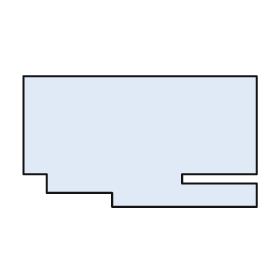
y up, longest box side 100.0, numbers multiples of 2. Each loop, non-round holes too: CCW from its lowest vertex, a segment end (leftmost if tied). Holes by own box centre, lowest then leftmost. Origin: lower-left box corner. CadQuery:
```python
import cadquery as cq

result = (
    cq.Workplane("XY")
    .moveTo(38.0, 0.0)
    .lineTo(100.0, 0.0)
    .lineTo(100.0, 10.0)
    .lineTo(68.0, 10.0)
    .lineTo(68.0, 14.0)
    .lineTo(100.0, 14.0)
    .lineTo(100.0, 56.0)
    .lineTo(0.0, 56.0)
    .lineTo(0.0, 14.0)
    .lineTo(10.0, 14.0)
    .lineTo(10.0, 6.0)
    .lineTo(38.0, 6.0)
    .close()
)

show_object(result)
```